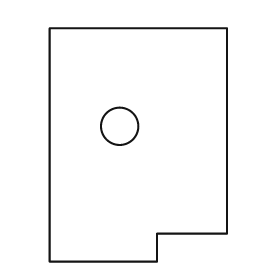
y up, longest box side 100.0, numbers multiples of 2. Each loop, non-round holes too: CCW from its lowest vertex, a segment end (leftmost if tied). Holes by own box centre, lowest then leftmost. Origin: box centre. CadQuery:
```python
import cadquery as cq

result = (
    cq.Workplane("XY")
    .moveTo(-38.0, -50.0)
    .lineTo(8.0, -50.0)
    .lineTo(8.0, -38.0)
    .lineTo(38.0, -38.0)
    .lineTo(38.0, 50.0)
    .lineTo(-38.0, 50.0)
    .close()
    .moveTo(-8.0, 8.0)
    .circle(8.0)
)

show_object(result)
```